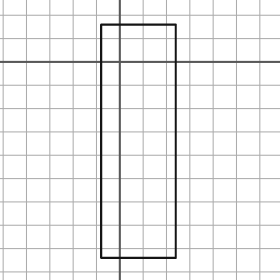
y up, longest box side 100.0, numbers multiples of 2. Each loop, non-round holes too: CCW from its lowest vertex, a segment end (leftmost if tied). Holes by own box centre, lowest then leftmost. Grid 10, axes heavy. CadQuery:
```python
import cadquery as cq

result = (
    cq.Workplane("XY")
    .moveTo(-8.0, -84.0)
    .lineTo(24.0, -84.0)
    .lineTo(24.0, 16.0)
    .lineTo(-8.0, 16.0)
    .close()
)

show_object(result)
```